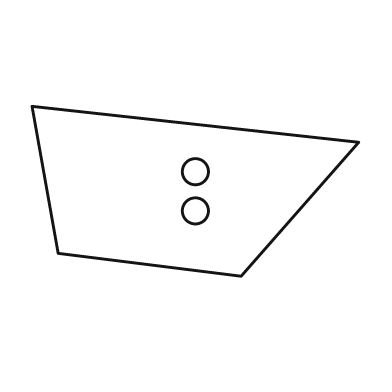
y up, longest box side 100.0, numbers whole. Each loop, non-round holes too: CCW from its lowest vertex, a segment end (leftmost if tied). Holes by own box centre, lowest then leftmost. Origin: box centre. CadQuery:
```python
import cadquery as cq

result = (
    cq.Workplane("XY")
    .moveTo(14.0, -26.0)
    .lineTo(50.0, 15.0)
    .lineTo(-50.0, 26.0)
    .lineTo(-42.0, -19.0)
    .close()
    .moveTo(0.0, -6.0)
    .circle(4.0)
    .moveTo(0.0, 6.0)
    .circle(4.0)
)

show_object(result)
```